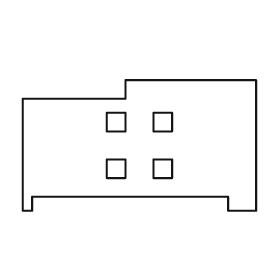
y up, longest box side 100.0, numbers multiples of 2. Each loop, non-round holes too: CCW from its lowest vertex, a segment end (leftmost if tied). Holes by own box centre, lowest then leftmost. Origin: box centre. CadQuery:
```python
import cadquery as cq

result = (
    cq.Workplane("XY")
    .moveTo(-50.0, -28.0)
    .lineTo(-46.0, -28.0)
    .lineTo(-46.0, -22.0)
    .lineTo(38.0, -22.0)
    .lineTo(38.0, -28.0)
    .lineTo(50.0, -28.0)
    .lineTo(50.0, 28.0)
    .lineTo(-6.0, 28.0)
    .lineTo(-6.0, 20.0)
    .lineTo(-50.0, 20.0)
    .close()
    .moveTo(-14.0, -14.0)
    .lineTo(-6.0, -14.0)
    .lineTo(-6.0, -6.0)
    .lineTo(-14.0, -6.0)
    .close()
    .moveTo(6.0, -14.0)
    .lineTo(14.0, -14.0)
    .lineTo(14.0, -6.0)
    .lineTo(6.0, -6.0)
    .close()
    .moveTo(-14.0, 6.0)
    .lineTo(-6.0, 6.0)
    .lineTo(-6.0, 14.0)
    .lineTo(-14.0, 14.0)
    .close()
    .moveTo(6.0, 6.0)
    .lineTo(14.0, 6.0)
    .lineTo(14.0, 14.0)
    .lineTo(6.0, 14.0)
    .close()
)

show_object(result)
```